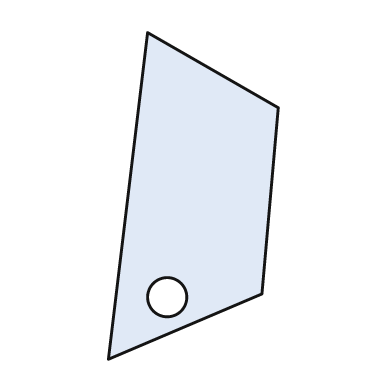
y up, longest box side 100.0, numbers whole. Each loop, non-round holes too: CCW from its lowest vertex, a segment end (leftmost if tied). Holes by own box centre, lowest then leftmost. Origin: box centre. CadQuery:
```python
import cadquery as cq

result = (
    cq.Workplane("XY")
    .moveTo(-26.0, -50.0)
    .lineTo(21.0, -30.0)
    .lineTo(26.0, 27.0)
    .lineTo(-14.0, 50.0)
    .close()
    .moveTo(-8.0, -31.0)
    .circle(6.0)
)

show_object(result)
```